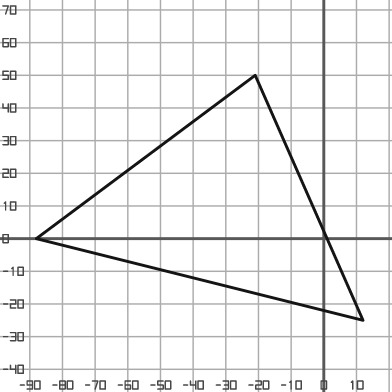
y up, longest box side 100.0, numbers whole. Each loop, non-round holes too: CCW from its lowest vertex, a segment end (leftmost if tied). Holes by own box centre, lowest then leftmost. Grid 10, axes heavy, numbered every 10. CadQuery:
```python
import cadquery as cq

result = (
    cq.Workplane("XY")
    .moveTo(12.0, -25.0)
    .lineTo(-21.0, 50.0)
    .lineTo(-88.0, 0.0)
    .close()
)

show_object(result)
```